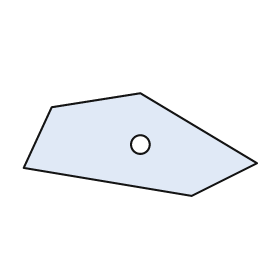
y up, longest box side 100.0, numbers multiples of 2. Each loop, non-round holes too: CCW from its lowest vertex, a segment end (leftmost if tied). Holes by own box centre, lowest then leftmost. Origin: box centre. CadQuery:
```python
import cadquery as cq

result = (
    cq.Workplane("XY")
    .moveTo(22.0, -22.0)
    .lineTo(50.0, -8.0)
    .lineTo(0.0, 22.0)
    .lineTo(-38.0, 16.0)
    .lineTo(-50.0, -10.0)
    .close()
    .moveTo(0.0, 0.0)
    .circle(4.0)
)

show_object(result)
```